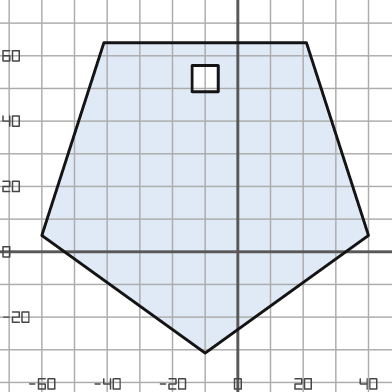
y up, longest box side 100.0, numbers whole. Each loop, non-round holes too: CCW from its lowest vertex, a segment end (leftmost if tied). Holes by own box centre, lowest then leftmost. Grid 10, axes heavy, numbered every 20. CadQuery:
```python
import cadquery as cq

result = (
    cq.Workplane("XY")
    .moveTo(-10.0, -31.0)
    .lineTo(40.0, 5.0)
    .lineTo(21.0, 64.0)
    .lineTo(-41.0, 64.0)
    .lineTo(-60.0, 5.0)
    .close()
    .moveTo(-14.0, 49.0)
    .lineTo(-6.0, 49.0)
    .lineTo(-6.0, 57.0)
    .lineTo(-14.0, 57.0)
    .close()
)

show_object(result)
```